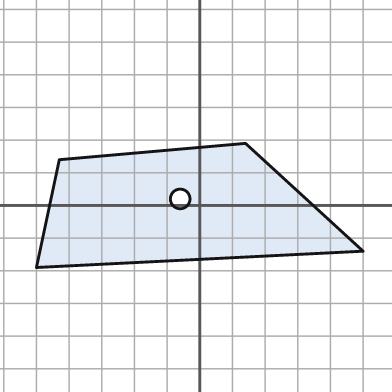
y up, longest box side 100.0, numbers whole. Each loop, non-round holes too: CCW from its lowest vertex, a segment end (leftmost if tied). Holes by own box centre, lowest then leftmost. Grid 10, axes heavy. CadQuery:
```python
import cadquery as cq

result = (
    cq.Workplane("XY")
    .moveTo(-50.0, -19.0)
    .lineTo(50.0, -14.0)
    .lineTo(14.0, 19.0)
    .lineTo(-43.0, 14.0)
    .close()
    .moveTo(-6.0, 2.0)
    .circle(3.0)
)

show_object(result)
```